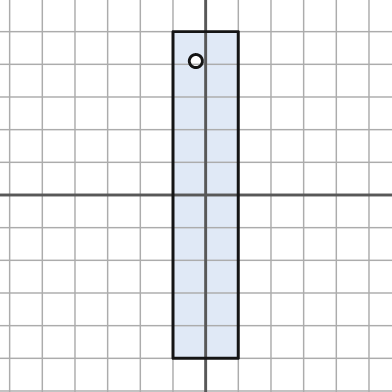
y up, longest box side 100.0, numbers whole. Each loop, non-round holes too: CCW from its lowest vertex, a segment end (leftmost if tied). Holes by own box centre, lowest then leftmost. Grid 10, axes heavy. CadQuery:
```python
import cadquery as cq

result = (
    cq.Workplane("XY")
    .moveTo(-10.0, -50.0)
    .lineTo(10.0, -50.0)
    .lineTo(10.0, 50.0)
    .lineTo(-10.0, 50.0)
    .close()
    .moveTo(-3.0, 41.0)
    .circle(2.0)
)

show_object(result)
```